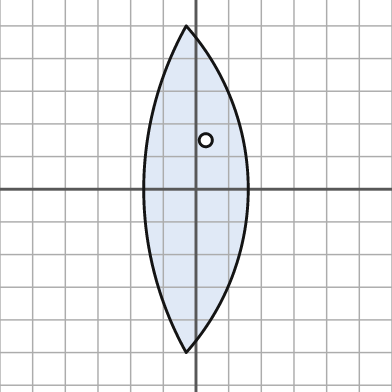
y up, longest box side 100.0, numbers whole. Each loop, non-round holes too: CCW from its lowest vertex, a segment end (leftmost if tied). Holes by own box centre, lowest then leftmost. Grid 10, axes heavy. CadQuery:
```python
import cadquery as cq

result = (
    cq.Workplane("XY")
    .moveTo(-3.0, -50.0)
    .threePointArc((16.0, 0.0), (-3.0, 50.0))
    .threePointArc((-16.0, 0.0), (-3.0, -50.0))
    .close()
    .moveTo(3.0, 15.0)
    .circle(2.0)
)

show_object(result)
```